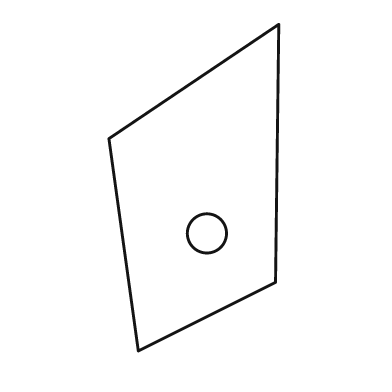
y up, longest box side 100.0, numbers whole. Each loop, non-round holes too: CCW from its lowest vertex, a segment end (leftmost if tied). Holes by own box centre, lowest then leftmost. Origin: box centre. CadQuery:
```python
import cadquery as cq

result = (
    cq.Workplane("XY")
    .moveTo(-17.0, -50.0)
    .lineTo(25.0, -29.0)
    .lineTo(26.0, 50.0)
    .lineTo(-26.0, 15.0)
    .close()
    .moveTo(4.0, -14.0)
    .circle(6.0)
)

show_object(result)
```